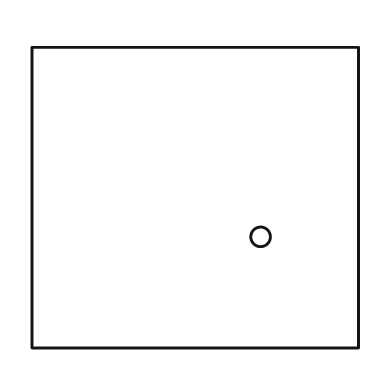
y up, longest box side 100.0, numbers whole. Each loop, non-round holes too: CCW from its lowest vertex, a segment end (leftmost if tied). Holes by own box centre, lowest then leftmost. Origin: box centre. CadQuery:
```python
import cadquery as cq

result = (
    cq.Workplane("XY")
    .moveTo(-50.0, -46.0)
    .lineTo(50.0, -46.0)
    .lineTo(50.0, 46.0)
    .lineTo(-50.0, 46.0)
    .close()
    .moveTo(20.0, -12.0)
    .circle(3.0)
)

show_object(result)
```